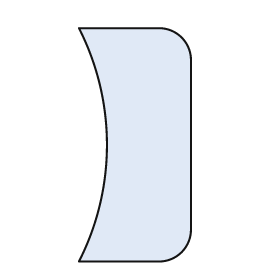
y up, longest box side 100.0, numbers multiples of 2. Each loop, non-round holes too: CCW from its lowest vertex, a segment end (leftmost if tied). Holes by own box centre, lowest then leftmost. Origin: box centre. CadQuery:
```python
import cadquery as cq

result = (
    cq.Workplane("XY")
    .moveTo(-24.0, -50.0)
    .lineTo(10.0, -50.0)
    .threePointArc((20.0, -46.0), (24.0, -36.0))
    .lineTo(24.0, 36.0)
    .threePointArc((20.0, 46.0), (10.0, 50.0))
    .lineTo(-24.0, 50.0)
    .threePointArc((-12.0, 0.0), (-24.0, -50.0))
    .close()
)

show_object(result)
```